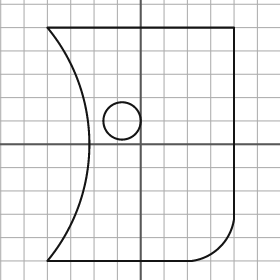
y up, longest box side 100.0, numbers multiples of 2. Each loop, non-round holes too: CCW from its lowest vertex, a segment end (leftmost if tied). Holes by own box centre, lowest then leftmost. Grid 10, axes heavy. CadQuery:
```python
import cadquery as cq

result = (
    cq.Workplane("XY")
    .moveTo(-40.0, -50.0)
    .lineTo(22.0, -50.0)
    .threePointArc((34.0, -44.0), (40.0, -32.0))
    .lineTo(40.0, 50.0)
    .lineTo(-40.0, 50.0)
    .threePointArc((-22.0, 0.0), (-40.0, -50.0))
    .close()
    .moveTo(-8.0, 10.0)
    .circle(8.0)
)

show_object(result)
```